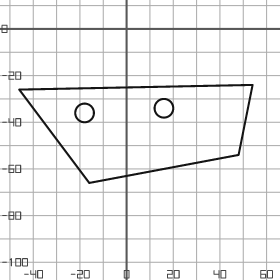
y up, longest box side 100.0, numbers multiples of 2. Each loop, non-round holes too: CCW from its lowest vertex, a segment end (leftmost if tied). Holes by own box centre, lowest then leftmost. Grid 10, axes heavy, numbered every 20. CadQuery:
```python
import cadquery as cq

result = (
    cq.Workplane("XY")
    .moveTo(-16.0, -66.0)
    .lineTo(48.0, -54.0)
    .lineTo(54.0, -24.0)
    .lineTo(-46.0, -26.0)
    .close()
    .moveTo(-18.0, -36.0)
    .circle(4.0)
    .moveTo(16.0, -34.0)
    .circle(4.0)
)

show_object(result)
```